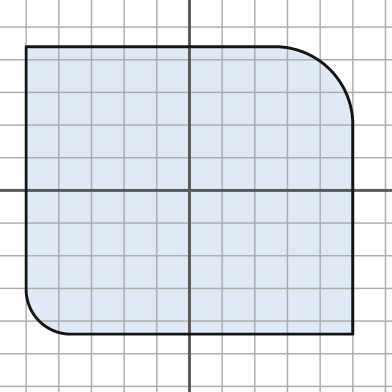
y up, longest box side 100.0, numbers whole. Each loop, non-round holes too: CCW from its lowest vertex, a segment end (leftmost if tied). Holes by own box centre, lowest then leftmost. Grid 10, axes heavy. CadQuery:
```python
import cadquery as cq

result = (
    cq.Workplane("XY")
    .moveTo(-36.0, -44.0)
    .lineTo(50.0, -44.0)
    .lineTo(50.0, 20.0)
    .threePointArc((43.0, 37.0), (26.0, 44.0))
    .lineTo(-50.0, 44.0)
    .lineTo(-50.0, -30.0)
    .threePointArc((-46.0, -40.0), (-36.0, -44.0))
    .close()
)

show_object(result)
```